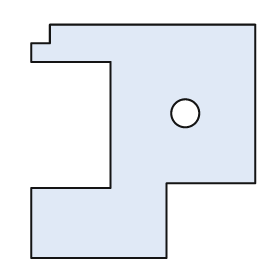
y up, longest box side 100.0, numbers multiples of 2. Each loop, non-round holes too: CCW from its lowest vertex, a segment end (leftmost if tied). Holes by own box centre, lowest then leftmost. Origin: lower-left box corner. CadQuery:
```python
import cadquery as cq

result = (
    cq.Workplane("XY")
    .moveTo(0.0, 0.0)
    .lineTo(58.0, 0.0)
    .lineTo(58.0, 32.0)
    .lineTo(96.0, 32.0)
    .lineTo(96.0, 100.0)
    .lineTo(8.0, 100.0)
    .lineTo(8.0, 92.0)
    .lineTo(0.0, 92.0)
    .lineTo(0.0, 84.0)
    .lineTo(34.0, 84.0)
    .lineTo(34.0, 30.0)
    .lineTo(0.0, 30.0)
    .close()
    .moveTo(66.0, 62.0)
    .circle(6.0)
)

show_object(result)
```